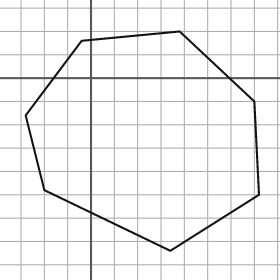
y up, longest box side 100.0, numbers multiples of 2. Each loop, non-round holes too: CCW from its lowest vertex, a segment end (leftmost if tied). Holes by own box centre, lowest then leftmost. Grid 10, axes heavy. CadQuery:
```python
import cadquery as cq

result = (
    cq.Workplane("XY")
    .moveTo(34.0, -74.0)
    .lineTo(72.0, -50.0)
    .lineTo(70.0, -10.0)
    .lineTo(38.0, 20.0)
    .lineTo(-4.0, 16.0)
    .lineTo(-28.0, -16.0)
    .lineTo(-20.0, -48.0)
    .close()
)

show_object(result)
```